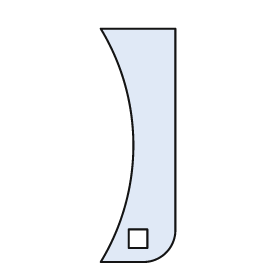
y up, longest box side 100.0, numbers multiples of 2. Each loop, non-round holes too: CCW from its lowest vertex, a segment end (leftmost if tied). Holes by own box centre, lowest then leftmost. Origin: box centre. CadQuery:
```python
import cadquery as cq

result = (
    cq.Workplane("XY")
    .moveTo(-16.0, -50.0)
    .lineTo(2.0, -50.0)
    .threePointArc((12.0, -46.0), (16.0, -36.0))
    .lineTo(16.0, 50.0)
    .lineTo(-16.0, 50.0)
    .threePointArc((-2.0, 0.0), (-16.0, -50.0))
    .close()
    .moveTo(-4.0, -44.0)
    .lineTo(4.0, -44.0)
    .lineTo(4.0, -36.0)
    .lineTo(-4.0, -36.0)
    .close()
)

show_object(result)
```